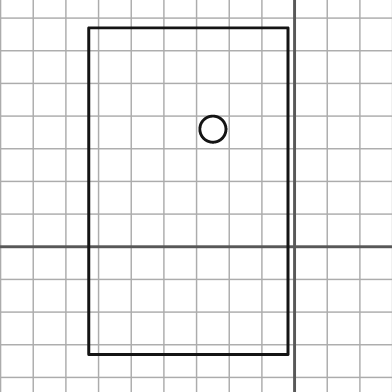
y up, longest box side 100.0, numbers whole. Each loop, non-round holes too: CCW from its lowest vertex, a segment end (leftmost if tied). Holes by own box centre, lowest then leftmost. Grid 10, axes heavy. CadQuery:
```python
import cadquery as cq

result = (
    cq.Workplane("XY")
    .moveTo(-63.0, -33.0)
    .lineTo(-2.0, -33.0)
    .lineTo(-2.0, 67.0)
    .lineTo(-63.0, 67.0)
    .close()
    .moveTo(-25.0, 36.0)
    .circle(4.0)
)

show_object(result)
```